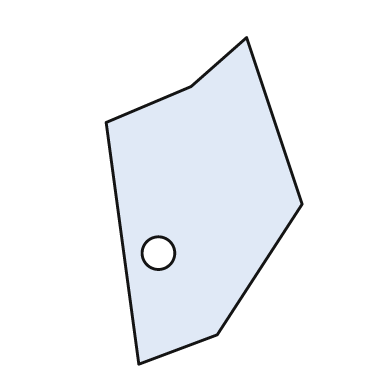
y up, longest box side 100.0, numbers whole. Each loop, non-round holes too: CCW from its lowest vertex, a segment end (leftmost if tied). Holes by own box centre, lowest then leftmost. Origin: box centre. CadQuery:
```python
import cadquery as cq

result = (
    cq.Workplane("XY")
    .moveTo(-20.0, -50.0)
    .lineTo(4.0, -41.0)
    .lineTo(30.0, -1.0)
    .lineTo(13.0, 50.0)
    .lineTo(-4.0, 35.0)
    .lineTo(-30.0, 24.0)
    .close()
    .moveTo(-14.0, -16.0)
    .circle(5.0)
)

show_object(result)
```